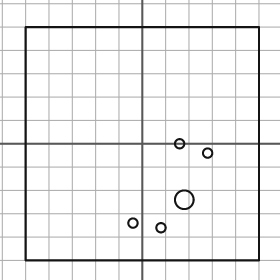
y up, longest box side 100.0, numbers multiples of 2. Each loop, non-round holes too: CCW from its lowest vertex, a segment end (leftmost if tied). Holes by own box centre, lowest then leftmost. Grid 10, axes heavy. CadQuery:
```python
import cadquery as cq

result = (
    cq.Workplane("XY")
    .moveTo(-50.0, -50.0)
    .lineTo(50.0, -50.0)
    .lineTo(50.0, 50.0)
    .lineTo(-50.0, 50.0)
    .close()
    .moveTo(8.0, -36.0)
    .circle(2.0)
    .moveTo(-4.0, -34.0)
    .circle(2.0)
    .moveTo(18.0, -24.0)
    .circle(4.0)
    .moveTo(28.0, -4.0)
    .circle(2.0)
    .moveTo(16.0, 0.0)
    .circle(2.0)
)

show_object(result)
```